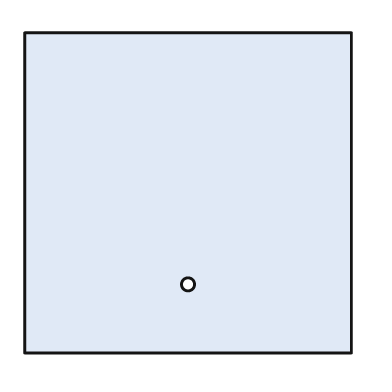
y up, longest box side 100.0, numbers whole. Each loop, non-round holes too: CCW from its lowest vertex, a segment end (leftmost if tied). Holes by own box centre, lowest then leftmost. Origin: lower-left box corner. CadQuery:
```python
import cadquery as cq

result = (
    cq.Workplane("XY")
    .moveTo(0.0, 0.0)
    .lineTo(100.0, 0.0)
    .lineTo(100.0, 98.0)
    .lineTo(0.0, 98.0)
    .close()
    .moveTo(50.0, 21.0)
    .circle(2.0)
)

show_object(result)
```